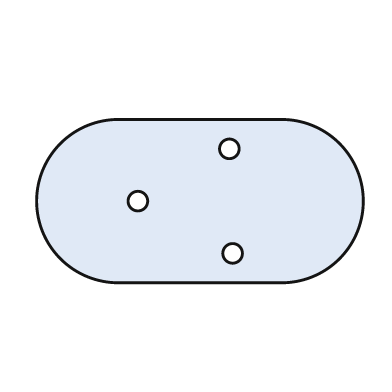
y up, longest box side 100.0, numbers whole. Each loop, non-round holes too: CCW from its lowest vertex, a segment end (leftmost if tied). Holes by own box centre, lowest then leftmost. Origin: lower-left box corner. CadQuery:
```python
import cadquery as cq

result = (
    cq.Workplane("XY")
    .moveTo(25.0, 0.0)
    .lineTo(75.0, 0.0)
    .threePointArc((100.0, 25.0), (75.0, 50.0))
    .lineTo(25.0, 50.0)
    .threePointArc((0.0, 25.0), (25.0, 0.0))
    .close()
    .moveTo(60.0, 9.0)
    .circle(3.0)
    .moveTo(31.0, 25.0)
    .circle(3.0)
    .moveTo(59.0, 41.0)
    .circle(3.0)
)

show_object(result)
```